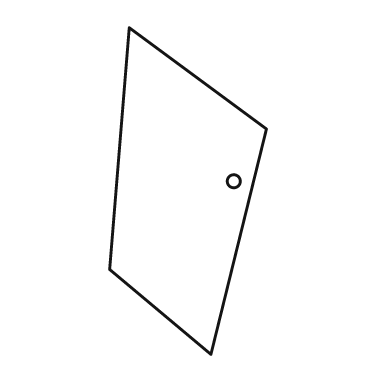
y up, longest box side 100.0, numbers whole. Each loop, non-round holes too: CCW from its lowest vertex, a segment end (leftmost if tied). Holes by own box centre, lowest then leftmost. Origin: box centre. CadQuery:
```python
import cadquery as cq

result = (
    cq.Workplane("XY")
    .moveTo(7.0, -50.0)
    .lineTo(24.0, 19.0)
    .lineTo(-18.0, 50.0)
    .lineTo(-24.0, -24.0)
    .close()
    .moveTo(14.0, 3.0)
    .circle(2.0)
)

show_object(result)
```